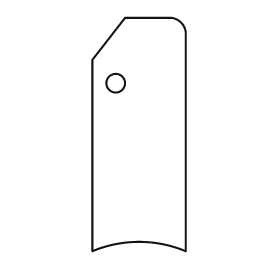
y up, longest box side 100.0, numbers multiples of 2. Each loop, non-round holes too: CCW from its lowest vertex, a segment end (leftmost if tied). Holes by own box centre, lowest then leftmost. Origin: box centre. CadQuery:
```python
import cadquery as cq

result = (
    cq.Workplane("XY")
    .moveTo(-20.0, -50.0)
    .threePointArc((0.0, -46.0), (20.0, -50.0))
    .lineTo(20.0, 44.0)
    .threePointArc((18.0, 48.0), (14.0, 50.0))
    .lineTo(-6.0, 50.0)
    .lineTo(-20.0, 32.0)
    .close()
    .moveTo(-10.0, 22.0)
    .circle(4.0)
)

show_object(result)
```